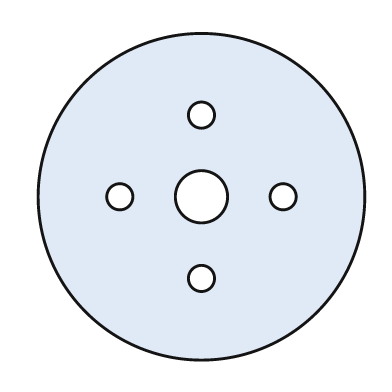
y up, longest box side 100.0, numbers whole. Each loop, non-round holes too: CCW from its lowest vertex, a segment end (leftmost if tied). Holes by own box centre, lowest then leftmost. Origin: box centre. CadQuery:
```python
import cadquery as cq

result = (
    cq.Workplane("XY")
    .moveTo(0.0, 0.0)
    .circle(50.0)
    .moveTo(0.0, -25.0)
    .circle(4.0)
    .moveTo(-25.0, 0.0)
    .circle(4.0)
    .moveTo(0.0, 0.0)
    .circle(8.0)
    .moveTo(25.0, 0.0)
    .circle(4.0)
    .moveTo(0.0, 25.0)
    .circle(4.0)
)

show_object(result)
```